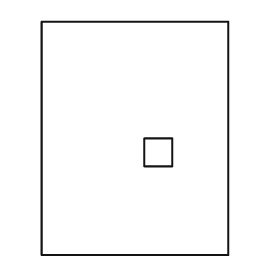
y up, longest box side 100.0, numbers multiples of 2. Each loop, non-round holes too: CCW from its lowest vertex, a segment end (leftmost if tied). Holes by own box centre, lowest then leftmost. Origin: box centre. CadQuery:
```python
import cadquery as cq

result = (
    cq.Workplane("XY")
    .moveTo(-40.0, -50.0)
    .lineTo(40.0, -50.0)
    .lineTo(40.0, 50.0)
    .lineTo(-40.0, 50.0)
    .close()
    .moveTo(4.0, -12.0)
    .lineTo(16.0, -12.0)
    .lineTo(16.0, 0.0)
    .lineTo(4.0, 0.0)
    .close()
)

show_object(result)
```